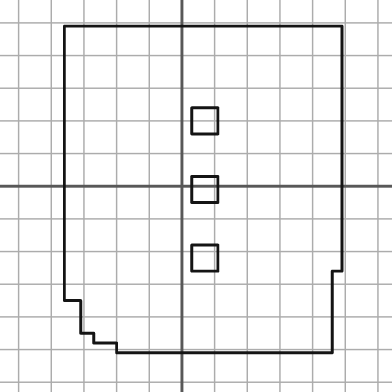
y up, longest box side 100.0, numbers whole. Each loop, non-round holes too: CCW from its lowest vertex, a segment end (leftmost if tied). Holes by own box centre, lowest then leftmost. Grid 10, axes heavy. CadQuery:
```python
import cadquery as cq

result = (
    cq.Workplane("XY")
    .moveTo(-20.0, -51.0)
    .lineTo(46.0, -51.0)
    .lineTo(46.0, -26.0)
    .lineTo(49.0, -26.0)
    .lineTo(49.0, 49.0)
    .lineTo(-36.0, 49.0)
    .lineTo(-36.0, -35.0)
    .lineTo(-31.0, -35.0)
    .lineTo(-31.0, -45.0)
    .lineTo(-27.0, -45.0)
    .lineTo(-27.0, -48.0)
    .lineTo(-20.0, -48.0)
    .close()
    .moveTo(3.0, -26.0)
    .lineTo(11.0, -26.0)
    .lineTo(11.0, -18.0)
    .lineTo(3.0, -18.0)
    .close()
    .moveTo(3.0, -5.0)
    .lineTo(11.0, -5.0)
    .lineTo(11.0, 3.0)
    .lineTo(3.0, 3.0)
    .close()
    .moveTo(3.0, 16.0)
    .lineTo(11.0, 16.0)
    .lineTo(11.0, 24.0)
    .lineTo(3.0, 24.0)
    .close()
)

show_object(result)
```